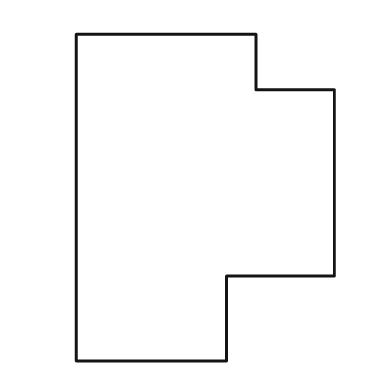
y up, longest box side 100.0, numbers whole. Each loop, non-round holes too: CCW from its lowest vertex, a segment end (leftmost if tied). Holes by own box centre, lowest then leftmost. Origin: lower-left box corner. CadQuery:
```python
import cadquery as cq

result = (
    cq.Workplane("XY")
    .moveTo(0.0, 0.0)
    .lineTo(46.0, 0.0)
    .lineTo(46.0, 26.0)
    .lineTo(79.0, 26.0)
    .lineTo(79.0, 83.0)
    .lineTo(55.0, 83.0)
    .lineTo(55.0, 100.0)
    .lineTo(0.0, 100.0)
    .close()
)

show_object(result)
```